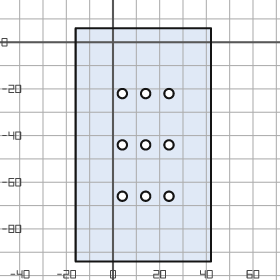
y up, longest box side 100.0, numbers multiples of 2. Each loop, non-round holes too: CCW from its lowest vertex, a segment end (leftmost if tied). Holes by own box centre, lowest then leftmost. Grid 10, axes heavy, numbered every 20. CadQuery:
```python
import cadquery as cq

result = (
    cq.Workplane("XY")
    .moveTo(-16.0, -94.0)
    .lineTo(42.0, -94.0)
    .lineTo(42.0, 6.0)
    .lineTo(-16.0, 6.0)
    .close()
    .moveTo(4.0, -66.0)
    .circle(2.0)
    .moveTo(14.0, -66.0)
    .circle(2.0)
    .moveTo(24.0, -66.0)
    .circle(2.0)
    .moveTo(4.0, -44.0)
    .circle(2.0)
    .moveTo(14.0, -44.0)
    .circle(2.0)
    .moveTo(24.0, -44.0)
    .circle(2.0)
    .moveTo(4.0, -22.0)
    .circle(2.0)
    .moveTo(14.0, -22.0)
    .circle(2.0)
    .moveTo(24.0, -22.0)
    .circle(2.0)
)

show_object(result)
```